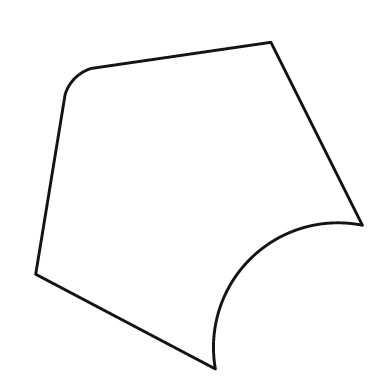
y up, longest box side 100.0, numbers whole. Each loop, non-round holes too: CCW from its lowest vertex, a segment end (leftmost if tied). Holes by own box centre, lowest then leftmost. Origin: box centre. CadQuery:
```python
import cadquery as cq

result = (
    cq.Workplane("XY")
    .moveTo(5.0, -50.0)
    .threePointArc((16.0, -16.0), (50.0, -6.0))
    .lineTo(22.0, 50.0)
    .lineTo(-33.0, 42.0)
    .threePointArc((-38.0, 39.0), (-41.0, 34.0))
    .lineTo(-50.0, -21.0)
    .close()
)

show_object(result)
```